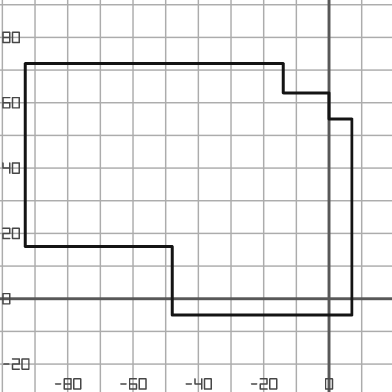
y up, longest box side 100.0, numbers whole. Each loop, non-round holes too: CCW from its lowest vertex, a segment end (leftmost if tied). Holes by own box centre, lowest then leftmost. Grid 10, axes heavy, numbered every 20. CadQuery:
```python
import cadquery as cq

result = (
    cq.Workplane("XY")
    .moveTo(-48.0, -5.0)
    .lineTo(7.0, -5.0)
    .lineTo(7.0, 55.0)
    .lineTo(0.0, 55.0)
    .lineTo(0.0, 63.0)
    .lineTo(-14.0, 63.0)
    .lineTo(-14.0, 72.0)
    .lineTo(-93.0, 72.0)
    .lineTo(-93.0, 16.0)
    .lineTo(-48.0, 16.0)
    .close()
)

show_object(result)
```